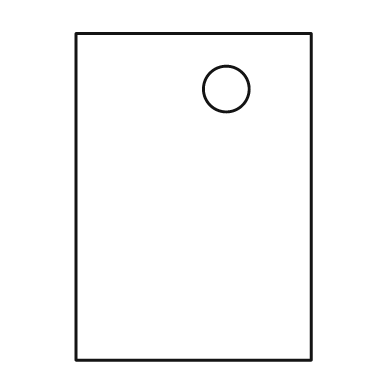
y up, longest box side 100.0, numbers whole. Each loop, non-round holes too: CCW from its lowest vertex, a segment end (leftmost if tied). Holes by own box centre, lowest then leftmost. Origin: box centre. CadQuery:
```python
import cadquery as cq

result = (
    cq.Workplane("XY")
    .moveTo(-36.0, -50.0)
    .lineTo(36.0, -50.0)
    .lineTo(36.0, 50.0)
    .lineTo(-36.0, 50.0)
    .close()
    .moveTo(10.0, 33.0)
    .circle(7.0)
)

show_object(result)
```